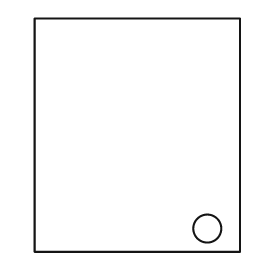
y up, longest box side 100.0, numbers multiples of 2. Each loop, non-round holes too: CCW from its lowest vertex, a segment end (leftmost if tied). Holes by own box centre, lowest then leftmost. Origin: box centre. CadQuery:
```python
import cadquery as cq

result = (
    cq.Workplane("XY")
    .moveTo(-44.0, -50.0)
    .lineTo(44.0, -50.0)
    .lineTo(44.0, 50.0)
    .lineTo(-44.0, 50.0)
    .close()
    .moveTo(30.0, -40.0)
    .circle(6.0)
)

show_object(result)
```